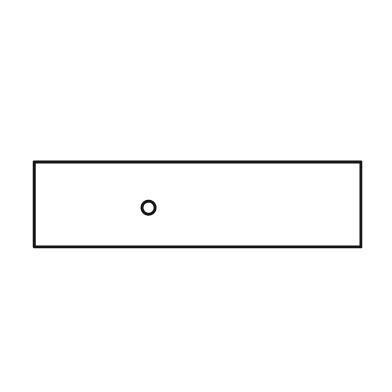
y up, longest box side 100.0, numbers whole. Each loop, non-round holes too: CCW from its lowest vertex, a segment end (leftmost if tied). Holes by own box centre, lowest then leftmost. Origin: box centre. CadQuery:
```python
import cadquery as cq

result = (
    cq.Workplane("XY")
    .moveTo(-50.0, -13.0)
    .lineTo(50.0, -13.0)
    .lineTo(50.0, 13.0)
    .lineTo(-50.0, 13.0)
    .close()
    .moveTo(-15.0, -1.0)
    .circle(2.0)
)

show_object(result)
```